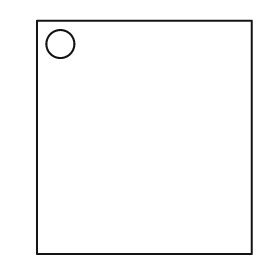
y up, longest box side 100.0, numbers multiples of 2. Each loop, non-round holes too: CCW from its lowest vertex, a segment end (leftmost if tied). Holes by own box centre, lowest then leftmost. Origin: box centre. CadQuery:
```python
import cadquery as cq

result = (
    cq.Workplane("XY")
    .moveTo(-46.0, -50.0)
    .lineTo(46.0, -50.0)
    .lineTo(46.0, 50.0)
    .lineTo(-46.0, 50.0)
    .close()
    .moveTo(-36.0, 40.0)
    .circle(6.0)
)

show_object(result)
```